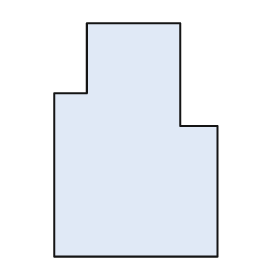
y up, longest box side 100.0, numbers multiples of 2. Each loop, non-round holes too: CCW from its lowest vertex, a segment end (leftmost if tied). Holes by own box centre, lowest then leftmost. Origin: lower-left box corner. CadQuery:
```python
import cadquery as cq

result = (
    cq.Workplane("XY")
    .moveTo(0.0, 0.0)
    .lineTo(70.0, 0.0)
    .lineTo(70.0, 56.0)
    .lineTo(54.0, 56.0)
    .lineTo(54.0, 100.0)
    .lineTo(14.0, 100.0)
    .lineTo(14.0, 70.0)
    .lineTo(0.0, 70.0)
    .close()
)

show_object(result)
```